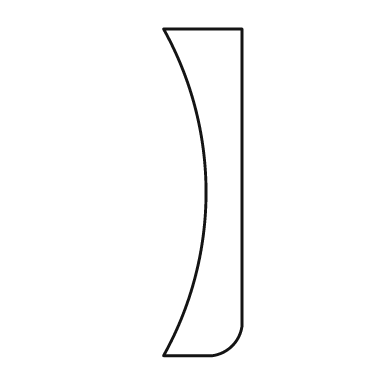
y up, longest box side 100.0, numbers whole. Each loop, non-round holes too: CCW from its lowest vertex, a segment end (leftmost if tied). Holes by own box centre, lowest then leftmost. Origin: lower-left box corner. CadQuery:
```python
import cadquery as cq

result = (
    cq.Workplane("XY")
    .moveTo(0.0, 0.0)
    .lineTo(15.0, 0.0)
    .threePointArc((21.0, 3.0), (24.0, 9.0))
    .lineTo(24.0, 100.0)
    .lineTo(0.0, 100.0)
    .threePointArc((13.0, 50.0), (0.0, 0.0))
    .close()
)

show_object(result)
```